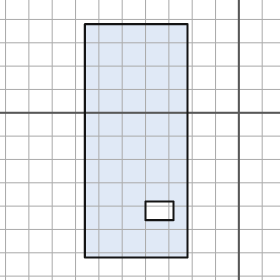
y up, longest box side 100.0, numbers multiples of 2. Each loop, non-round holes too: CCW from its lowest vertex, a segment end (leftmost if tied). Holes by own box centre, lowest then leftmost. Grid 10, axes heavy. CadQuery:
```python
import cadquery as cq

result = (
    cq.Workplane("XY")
    .moveTo(-66.0, -62.0)
    .lineTo(-22.0, -62.0)
    .lineTo(-22.0, 38.0)
    .lineTo(-66.0, 38.0)
    .close()
    .moveTo(-40.0, -46.0)
    .lineTo(-28.0, -46.0)
    .lineTo(-28.0, -38.0)
    .lineTo(-40.0, -38.0)
    .close()
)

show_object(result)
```